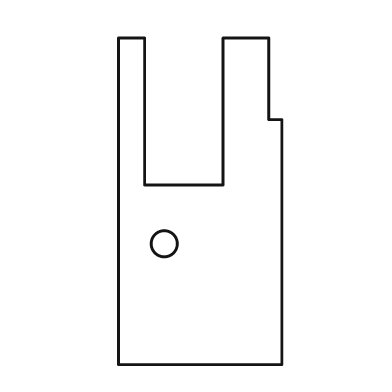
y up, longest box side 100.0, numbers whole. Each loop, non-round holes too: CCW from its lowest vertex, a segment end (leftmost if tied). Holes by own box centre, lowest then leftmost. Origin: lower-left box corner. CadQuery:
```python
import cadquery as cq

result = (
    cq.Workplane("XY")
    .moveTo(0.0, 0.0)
    .lineTo(50.0, 0.0)
    .lineTo(50.0, 75.0)
    .lineTo(46.0, 75.0)
    .lineTo(46.0, 100.0)
    .lineTo(32.0, 100.0)
    .lineTo(32.0, 55.0)
    .lineTo(8.0, 55.0)
    .lineTo(8.0, 100.0)
    .lineTo(0.0, 100.0)
    .close()
    .moveTo(14.0, 37.0)
    .circle(4.0)
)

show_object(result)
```